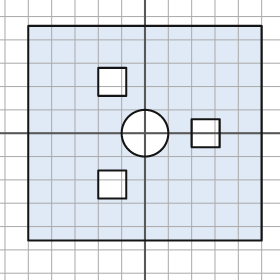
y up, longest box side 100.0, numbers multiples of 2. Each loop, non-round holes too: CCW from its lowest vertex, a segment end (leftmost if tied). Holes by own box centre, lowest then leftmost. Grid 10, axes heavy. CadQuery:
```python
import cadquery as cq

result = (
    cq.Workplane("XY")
    .moveTo(-50.0, -46.0)
    .lineTo(50.0, -46.0)
    .lineTo(50.0, 46.0)
    .lineTo(-50.0, 46.0)
    .close()
    .moveTo(-20.0, -28.0)
    .lineTo(-8.0, -28.0)
    .lineTo(-8.0, -16.0)
    .lineTo(-20.0, -16.0)
    .close()
    .moveTo(0.0, 0.0)
    .circle(10.0)
    .moveTo(20.0, -6.0)
    .lineTo(32.0, -6.0)
    .lineTo(32.0, 6.0)
    .lineTo(20.0, 6.0)
    .close()
    .moveTo(-20.0, 16.0)
    .lineTo(-8.0, 16.0)
    .lineTo(-8.0, 28.0)
    .lineTo(-20.0, 28.0)
    .close()
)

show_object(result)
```